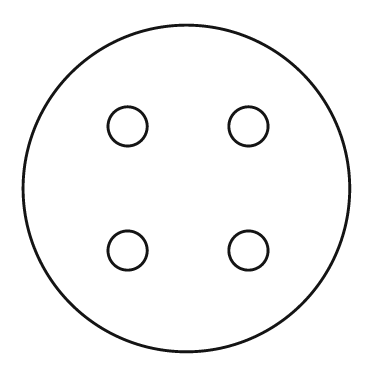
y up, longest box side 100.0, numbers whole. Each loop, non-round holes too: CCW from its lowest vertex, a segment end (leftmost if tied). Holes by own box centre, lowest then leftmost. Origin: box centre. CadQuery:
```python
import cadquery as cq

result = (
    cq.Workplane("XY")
    .moveTo(0.0, 0.0)
    .circle(50.0)
    .moveTo(-18.0, -19.0)
    .circle(6.0)
    .moveTo(19.0, -19.0)
    .circle(6.0)
    .moveTo(-18.0, 19.0)
    .circle(6.0)
    .moveTo(19.0, 19.0)
    .circle(6.0)
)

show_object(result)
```